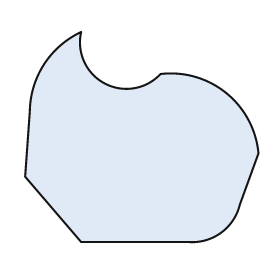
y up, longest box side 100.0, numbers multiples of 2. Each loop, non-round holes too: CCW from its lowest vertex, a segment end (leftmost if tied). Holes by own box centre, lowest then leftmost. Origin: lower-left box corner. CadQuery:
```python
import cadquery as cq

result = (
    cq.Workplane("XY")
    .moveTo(24.0, 0.0)
    .lineTo(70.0, 0.0)
    .threePointArc((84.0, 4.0), (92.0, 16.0))
    .lineTo(100.0, 38.0)
    .threePointArc((86.0, 64.0), (58.0, 72.0))
    .threePointArc((34.0, 68.0), (24.0, 90.0))
    .threePointArc((8.0, 76.0), (2.0, 56.0))
    .lineTo(0.0, 28.0)
    .close()
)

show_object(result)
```